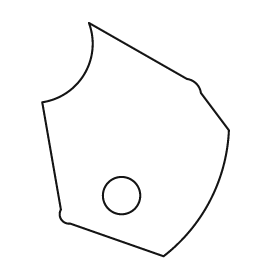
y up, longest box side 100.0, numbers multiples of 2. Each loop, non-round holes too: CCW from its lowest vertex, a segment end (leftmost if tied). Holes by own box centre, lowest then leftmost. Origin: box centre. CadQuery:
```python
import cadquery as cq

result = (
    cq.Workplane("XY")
    .moveTo(12.0, -50.0)
    .threePointArc((32.0, -26.0), (40.0, 4.0))
    .lineTo(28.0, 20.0)
    .threePointArc((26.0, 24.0), (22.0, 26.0))
    .lineTo(-20.0, 50.0)
    .threePointArc((-22.0, 28.0), (-40.0, 16.0))
    .lineTo(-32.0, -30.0)
    .threePointArc((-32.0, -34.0), (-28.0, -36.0))
    .close()
    .moveTo(-6.0, -24.0)
    .circle(8.0)
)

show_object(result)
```